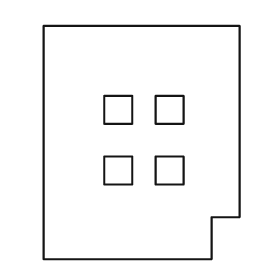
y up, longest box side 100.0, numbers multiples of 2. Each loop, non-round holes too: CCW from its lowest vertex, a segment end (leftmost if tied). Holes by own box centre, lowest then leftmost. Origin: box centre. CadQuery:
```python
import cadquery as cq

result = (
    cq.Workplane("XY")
    .moveTo(-42.0, -50.0)
    .lineTo(30.0, -50.0)
    .lineTo(30.0, -32.0)
    .lineTo(42.0, -32.0)
    .lineTo(42.0, 50.0)
    .lineTo(-42.0, 50.0)
    .close()
    .moveTo(-16.0, -18.0)
    .lineTo(-4.0, -18.0)
    .lineTo(-4.0, -6.0)
    .lineTo(-16.0, -6.0)
    .close()
    .moveTo(6.0, -18.0)
    .lineTo(18.0, -18.0)
    .lineTo(18.0, -6.0)
    .lineTo(6.0, -6.0)
    .close()
    .moveTo(-16.0, 8.0)
    .lineTo(-4.0, 8.0)
    .lineTo(-4.0, 20.0)
    .lineTo(-16.0, 20.0)
    .close()
    .moveTo(6.0, 8.0)
    .lineTo(18.0, 8.0)
    .lineTo(18.0, 20.0)
    .lineTo(6.0, 20.0)
    .close()
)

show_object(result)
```